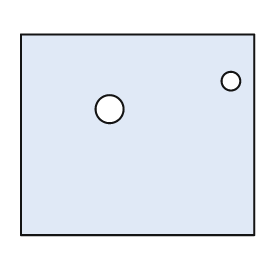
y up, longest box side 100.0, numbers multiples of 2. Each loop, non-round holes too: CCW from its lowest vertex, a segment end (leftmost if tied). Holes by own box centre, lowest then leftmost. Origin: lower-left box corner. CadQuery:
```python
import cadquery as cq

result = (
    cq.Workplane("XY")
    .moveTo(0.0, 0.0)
    .lineTo(100.0, 0.0)
    .lineTo(100.0, 86.0)
    .lineTo(0.0, 86.0)
    .close()
    .moveTo(38.0, 54.0)
    .circle(6.0)
    .moveTo(90.0, 66.0)
    .circle(4.0)
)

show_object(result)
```